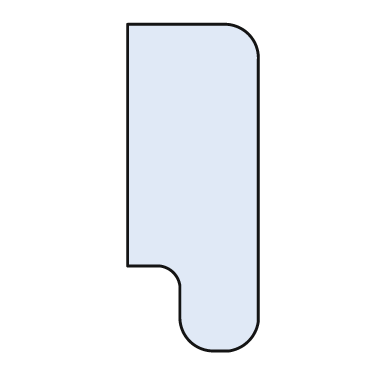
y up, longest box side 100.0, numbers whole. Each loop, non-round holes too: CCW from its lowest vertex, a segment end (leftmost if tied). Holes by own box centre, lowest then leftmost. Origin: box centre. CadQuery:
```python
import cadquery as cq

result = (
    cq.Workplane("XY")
    .moveTo(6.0, -50.0)
    .lineTo(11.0, -50.0)
    .threePointArc((17.0, -47.0), (20.0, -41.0))
    .lineTo(20.0, 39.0)
    .threePointArc((17.0, 47.0), (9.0, 50.0))
    .lineTo(-20.0, 50.0)
    .lineTo(-20.0, -24.0)
    .lineTo(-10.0, -24.0)
    .threePointArc((-6.0, -26.0), (-4.0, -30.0))
    .lineTo(-4.0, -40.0)
    .threePointArc((-1.0, -47.0), (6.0, -50.0))
    .close()
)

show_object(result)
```